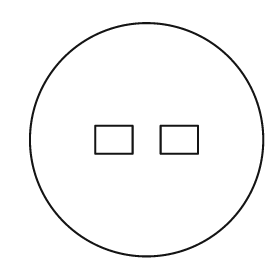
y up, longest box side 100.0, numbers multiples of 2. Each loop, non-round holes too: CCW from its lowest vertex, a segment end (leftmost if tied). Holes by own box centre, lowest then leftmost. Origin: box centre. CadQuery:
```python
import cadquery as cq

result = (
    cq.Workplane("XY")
    .moveTo(0.0, 0.0)
    .circle(50.0)
    .moveTo(-22.0, -6.0)
    .lineTo(-6.0, -6.0)
    .lineTo(-6.0, 6.0)
    .lineTo(-22.0, 6.0)
    .close()
    .moveTo(6.0, -6.0)
    .lineTo(22.0, -6.0)
    .lineTo(22.0, 6.0)
    .lineTo(6.0, 6.0)
    .close()
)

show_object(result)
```